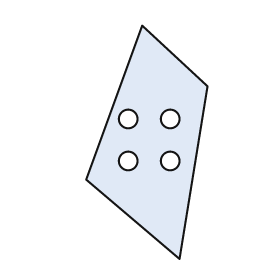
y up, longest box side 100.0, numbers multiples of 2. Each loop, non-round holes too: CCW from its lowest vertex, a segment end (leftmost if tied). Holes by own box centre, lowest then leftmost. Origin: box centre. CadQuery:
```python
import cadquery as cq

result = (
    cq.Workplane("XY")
    .moveTo(14.0, -50.0)
    .lineTo(26.0, 24.0)
    .lineTo(-2.0, 50.0)
    .lineTo(-26.0, -16.0)
    .close()
    .moveTo(-8.0, -8.0)
    .circle(4.0)
    .moveTo(10.0, -8.0)
    .circle(4.0)
    .moveTo(-8.0, 10.0)
    .circle(4.0)
    .moveTo(10.0, 10.0)
    .circle(4.0)
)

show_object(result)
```